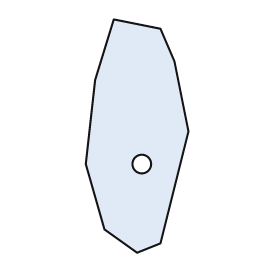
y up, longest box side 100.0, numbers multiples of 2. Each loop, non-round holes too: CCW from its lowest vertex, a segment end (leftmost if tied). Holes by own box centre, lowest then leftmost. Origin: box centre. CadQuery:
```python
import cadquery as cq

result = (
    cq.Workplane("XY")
    .moveTo(0.0, -50.0)
    .lineTo(10.0, -46.0)
    .lineTo(22.0, 2.0)
    .lineTo(16.0, 32.0)
    .lineTo(10.0, 46.0)
    .lineTo(-10.0, 50.0)
    .lineTo(-18.0, 24.0)
    .lineTo(-22.0, -12.0)
    .lineTo(-14.0, -40.0)
    .close()
    .moveTo(2.0, -12.0)
    .circle(4.0)
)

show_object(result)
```